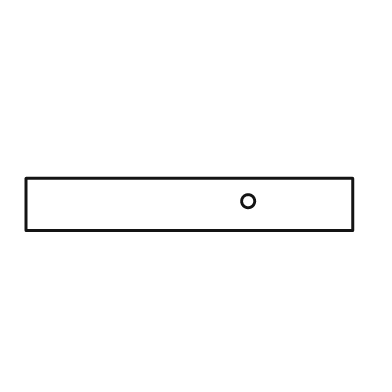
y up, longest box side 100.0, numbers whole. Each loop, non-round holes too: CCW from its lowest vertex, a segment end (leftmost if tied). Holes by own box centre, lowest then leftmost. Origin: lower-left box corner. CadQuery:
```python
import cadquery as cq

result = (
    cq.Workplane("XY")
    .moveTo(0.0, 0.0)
    .lineTo(100.0, 0.0)
    .lineTo(100.0, 16.0)
    .lineTo(0.0, 16.0)
    .close()
    .moveTo(68.0, 9.0)
    .circle(2.0)
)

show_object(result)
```